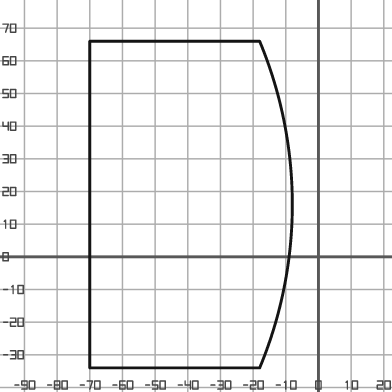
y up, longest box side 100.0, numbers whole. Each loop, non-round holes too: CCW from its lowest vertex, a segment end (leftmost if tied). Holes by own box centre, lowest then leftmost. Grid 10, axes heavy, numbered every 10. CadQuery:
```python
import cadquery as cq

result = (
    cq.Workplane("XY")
    .moveTo(-70.0, -34.0)
    .lineTo(-18.0, -34.0)
    .threePointArc((-8.0, 16.0), (-18.0, 66.0))
    .lineTo(-70.0, 66.0)
    .close()
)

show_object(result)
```